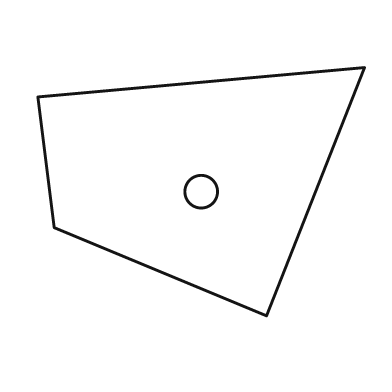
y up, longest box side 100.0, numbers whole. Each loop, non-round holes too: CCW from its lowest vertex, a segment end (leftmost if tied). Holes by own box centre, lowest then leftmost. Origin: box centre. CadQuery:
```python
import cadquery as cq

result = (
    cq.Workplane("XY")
    .moveTo(20.0, -38.0)
    .lineTo(50.0, 38.0)
    .lineTo(-50.0, 29.0)
    .lineTo(-45.0, -11.0)
    .close()
    .moveTo(0.0, 0.0)
    .circle(5.0)
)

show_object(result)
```